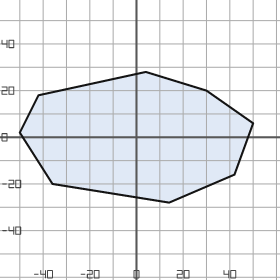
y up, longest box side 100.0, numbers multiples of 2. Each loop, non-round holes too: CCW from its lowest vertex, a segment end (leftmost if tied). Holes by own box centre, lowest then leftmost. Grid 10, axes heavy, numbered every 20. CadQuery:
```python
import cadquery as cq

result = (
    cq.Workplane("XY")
    .moveTo(14.0, -28.0)
    .lineTo(42.0, -16.0)
    .lineTo(50.0, 6.0)
    .lineTo(30.0, 20.0)
    .lineTo(4.0, 28.0)
    .lineTo(-42.0, 18.0)
    .lineTo(-50.0, 2.0)
    .lineTo(-36.0, -20.0)
    .close()
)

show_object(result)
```